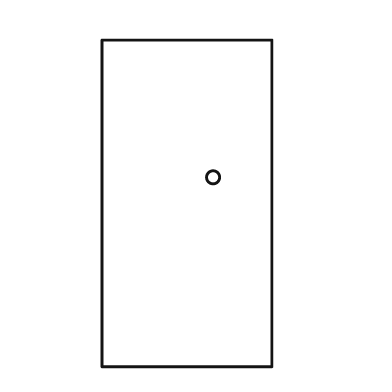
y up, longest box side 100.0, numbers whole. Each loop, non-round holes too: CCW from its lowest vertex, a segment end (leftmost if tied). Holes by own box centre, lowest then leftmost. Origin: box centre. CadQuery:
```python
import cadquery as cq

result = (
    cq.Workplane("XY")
    .moveTo(-26.0, -50.0)
    .lineTo(26.0, -50.0)
    .lineTo(26.0, 50.0)
    .lineTo(-26.0, 50.0)
    .close()
    .moveTo(8.0, 8.0)
    .circle(2.0)
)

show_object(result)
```